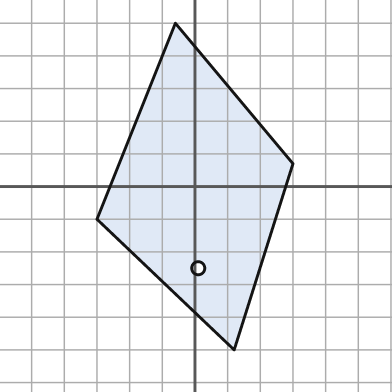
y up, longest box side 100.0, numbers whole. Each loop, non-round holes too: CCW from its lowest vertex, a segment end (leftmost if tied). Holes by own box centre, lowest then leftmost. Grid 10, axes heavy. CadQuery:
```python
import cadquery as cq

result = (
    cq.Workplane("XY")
    .moveTo(12.0, -50.0)
    .lineTo(30.0, 7.0)
    .lineTo(-6.0, 50.0)
    .lineTo(-30.0, -10.0)
    .close()
    .moveTo(1.0, -25.0)
    .circle(2.0)
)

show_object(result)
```